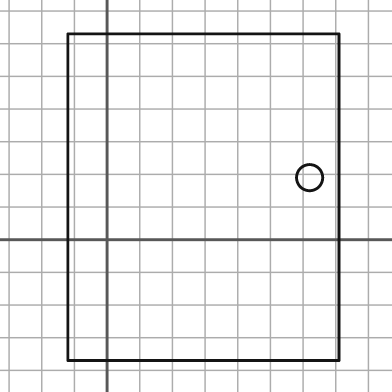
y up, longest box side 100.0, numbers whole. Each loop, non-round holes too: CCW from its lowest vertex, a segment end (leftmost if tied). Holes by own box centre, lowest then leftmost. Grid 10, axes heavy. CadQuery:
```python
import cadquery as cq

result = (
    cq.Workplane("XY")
    .moveTo(-12.0, -37.0)
    .lineTo(71.0, -37.0)
    .lineTo(71.0, 63.0)
    .lineTo(-12.0, 63.0)
    .close()
    .moveTo(62.0, 19.0)
    .circle(4.0)
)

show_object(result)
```